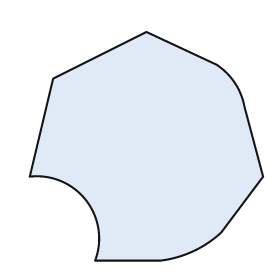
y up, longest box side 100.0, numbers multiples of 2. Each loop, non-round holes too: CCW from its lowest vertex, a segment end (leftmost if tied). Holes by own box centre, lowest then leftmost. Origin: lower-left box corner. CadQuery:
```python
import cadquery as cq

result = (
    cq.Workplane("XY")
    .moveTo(28.0, 0.0)
    .lineTo(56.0, 0.0)
    .threePointArc((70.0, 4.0), (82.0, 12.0))
    .lineTo(100.0, 36.0)
    .lineTo(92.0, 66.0)
    .threePointArc((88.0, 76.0), (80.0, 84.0))
    .lineTo(50.0, 98.0)
    .lineTo(10.0, 78.0)
    .lineTo(0.0, 36.0)
    .threePointArc((24.0, 26.0), (28.0, 0.0))
    .close()
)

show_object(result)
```